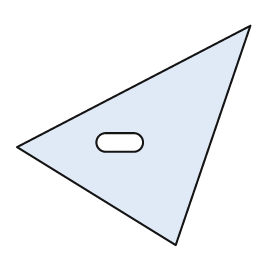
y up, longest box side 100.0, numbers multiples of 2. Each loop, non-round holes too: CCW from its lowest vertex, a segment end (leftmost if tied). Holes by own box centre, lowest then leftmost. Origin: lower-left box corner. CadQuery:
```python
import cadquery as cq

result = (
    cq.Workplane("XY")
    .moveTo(68.0, 0.0)
    .lineTo(100.0, 94.0)
    .lineTo(0.0, 42.0)
    .close()
    .moveTo(38.0, 40.0)
    .lineTo(50.0, 40.0)
    .threePointArc((54.0, 44.0), (50.0, 48.0))
    .lineTo(38.0, 48.0)
    .threePointArc((34.0, 44.0), (38.0, 40.0))
    .close()
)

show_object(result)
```